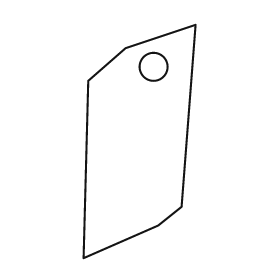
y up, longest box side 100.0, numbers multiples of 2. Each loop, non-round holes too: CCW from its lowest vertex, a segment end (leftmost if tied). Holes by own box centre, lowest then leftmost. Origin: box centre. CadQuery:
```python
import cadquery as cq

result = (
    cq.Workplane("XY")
    .moveTo(-24.0, -50.0)
    .lineTo(8.0, -36.0)
    .lineTo(18.0, -28.0)
    .lineTo(24.0, 50.0)
    .lineTo(-6.0, 40.0)
    .lineTo(-22.0, 26.0)
    .close()
    .moveTo(6.0, 32.0)
    .circle(6.0)
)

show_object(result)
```